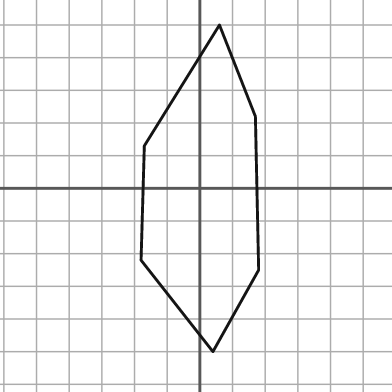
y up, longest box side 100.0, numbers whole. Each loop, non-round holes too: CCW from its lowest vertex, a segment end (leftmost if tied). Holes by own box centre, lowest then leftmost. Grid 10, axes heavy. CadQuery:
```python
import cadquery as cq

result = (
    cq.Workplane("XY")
    .moveTo(4.0, -50.0)
    .lineTo(18.0, -25.0)
    .lineTo(17.0, 22.0)
    .lineTo(6.0, 50.0)
    .lineTo(-17.0, 13.0)
    .lineTo(-18.0, -22.0)
    .close()
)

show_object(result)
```